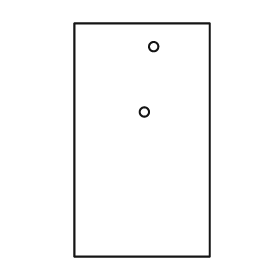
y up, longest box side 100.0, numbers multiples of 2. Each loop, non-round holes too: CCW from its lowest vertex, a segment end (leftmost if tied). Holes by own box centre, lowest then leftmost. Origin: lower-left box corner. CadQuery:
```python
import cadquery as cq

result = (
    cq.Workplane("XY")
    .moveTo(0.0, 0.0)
    .lineTo(58.0, 0.0)
    .lineTo(58.0, 100.0)
    .lineTo(0.0, 100.0)
    .close()
    .moveTo(30.0, 62.0)
    .circle(2.0)
    .moveTo(34.0, 90.0)
    .circle(2.0)
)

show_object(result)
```